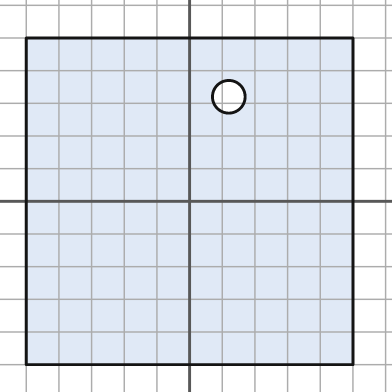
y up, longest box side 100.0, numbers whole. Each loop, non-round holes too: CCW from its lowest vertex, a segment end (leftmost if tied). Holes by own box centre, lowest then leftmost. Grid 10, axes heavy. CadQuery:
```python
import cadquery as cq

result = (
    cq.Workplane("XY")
    .moveTo(-50.0, -50.0)
    .lineTo(50.0, -50.0)
    .lineTo(50.0, 50.0)
    .lineTo(-50.0, 50.0)
    .close()
    .moveTo(12.0, 32.0)
    .circle(5.0)
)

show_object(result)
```